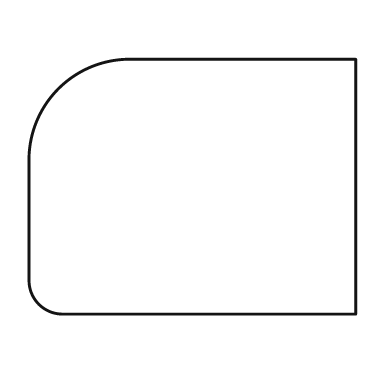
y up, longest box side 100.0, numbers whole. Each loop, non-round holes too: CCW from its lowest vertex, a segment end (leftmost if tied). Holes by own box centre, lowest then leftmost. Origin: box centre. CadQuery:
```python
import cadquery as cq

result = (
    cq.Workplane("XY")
    .moveTo(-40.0, -39.0)
    .lineTo(50.0, -39.0)
    .lineTo(50.0, 39.0)
    .lineTo(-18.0, 39.0)
    .threePointArc((-41.0, 30.0), (-50.0, 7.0))
    .lineTo(-50.0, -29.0)
    .threePointArc((-47.0, -36.0), (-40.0, -39.0))
    .close()
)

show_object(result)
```